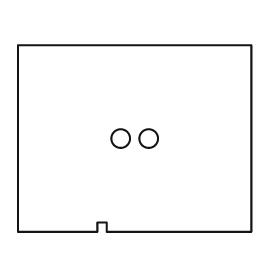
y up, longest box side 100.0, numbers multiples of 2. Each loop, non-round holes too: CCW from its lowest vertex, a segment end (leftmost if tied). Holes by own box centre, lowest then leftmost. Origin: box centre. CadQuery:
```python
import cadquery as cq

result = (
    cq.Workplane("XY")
    .moveTo(-50.0, -40.0)
    .lineTo(-16.0, -40.0)
    .lineTo(-16.0, -36.0)
    .lineTo(-12.0, -36.0)
    .lineTo(-12.0, -40.0)
    .lineTo(50.0, -40.0)
    .lineTo(50.0, 40.0)
    .lineTo(-50.0, 40.0)
    .close()
    .moveTo(-6.0, 0.0)
    .circle(4.0)
    .moveTo(6.0, 0.0)
    .circle(4.0)
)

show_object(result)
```